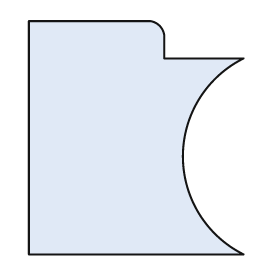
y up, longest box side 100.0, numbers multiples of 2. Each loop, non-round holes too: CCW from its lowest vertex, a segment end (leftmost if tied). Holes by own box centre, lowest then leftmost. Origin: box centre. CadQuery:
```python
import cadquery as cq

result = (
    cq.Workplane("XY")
    .moveTo(-46.0, -50.0)
    .lineTo(46.0, -50.0)
    .threePointArc((20.0, -8.0), (46.0, 34.0))
    .lineTo(12.0, 34.0)
    .lineTo(12.0, 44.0)
    .threePointArc((10.0, 48.0), (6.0, 50.0))
    .lineTo(-46.0, 50.0)
    .close()
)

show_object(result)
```